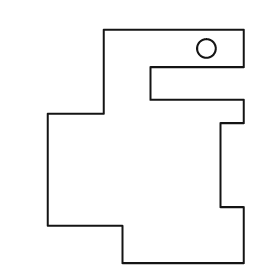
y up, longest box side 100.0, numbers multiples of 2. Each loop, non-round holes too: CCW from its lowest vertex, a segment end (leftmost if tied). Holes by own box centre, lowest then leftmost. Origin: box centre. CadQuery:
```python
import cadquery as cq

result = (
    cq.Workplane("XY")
    .moveTo(-10.0, -50.0)
    .lineTo(42.0, -50.0)
    .lineTo(42.0, -26.0)
    .lineTo(32.0, -26.0)
    .lineTo(32.0, 10.0)
    .lineTo(42.0, 10.0)
    .lineTo(42.0, 20.0)
    .lineTo(2.0, 20.0)
    .lineTo(2.0, 34.0)
    .lineTo(42.0, 34.0)
    .lineTo(42.0, 50.0)
    .lineTo(-18.0, 50.0)
    .lineTo(-18.0, 14.0)
    .lineTo(-42.0, 14.0)
    .lineTo(-42.0, -34.0)
    .lineTo(-10.0, -34.0)
    .close()
    .moveTo(26.0, 42.0)
    .circle(4.0)
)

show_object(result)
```